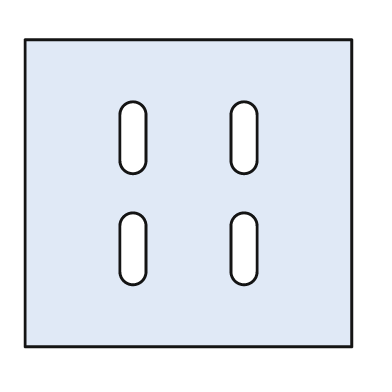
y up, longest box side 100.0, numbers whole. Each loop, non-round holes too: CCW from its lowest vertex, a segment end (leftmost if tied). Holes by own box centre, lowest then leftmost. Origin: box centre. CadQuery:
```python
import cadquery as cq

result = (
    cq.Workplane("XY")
    .moveTo(-50.0, -47.0)
    .lineTo(50.0, -47.0)
    .lineTo(50.0, 47.0)
    .lineTo(-50.0, 47.0)
    .close()
    .moveTo(-21.0, -24.0)
    .threePointArc((-17.0, -28.0), (-13.0, -24.0))
    .lineTo(-13.0, -10.0)
    .threePointArc((-17.0, -6.0), (-21.0, -10.0))
    .close()
    .moveTo(13.0, -24.0)
    .threePointArc((17.0, -28.0), (21.0, -24.0))
    .lineTo(21.0, -10.0)
    .threePointArc((17.0, -6.0), (13.0, -10.0))
    .close()
    .moveTo(-21.0, 10.0)
    .threePointArc((-17.0, 6.0), (-13.0, 10.0))
    .lineTo(-13.0, 24.0)
    .threePointArc((-17.0, 28.0), (-21.0, 24.0))
    .close()
    .moveTo(13.0, 10.0)
    .threePointArc((17.0, 6.0), (21.0, 10.0))
    .lineTo(21.0, 24.0)
    .threePointArc((17.0, 28.0), (13.0, 24.0))
    .close()
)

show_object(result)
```